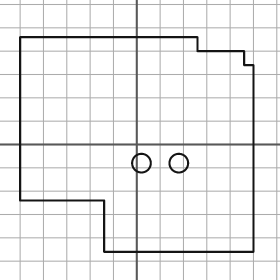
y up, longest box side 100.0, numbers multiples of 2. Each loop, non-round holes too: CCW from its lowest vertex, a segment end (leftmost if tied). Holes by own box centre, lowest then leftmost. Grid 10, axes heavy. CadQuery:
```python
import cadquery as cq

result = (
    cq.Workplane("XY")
    .moveTo(-14.0, -46.0)
    .lineTo(50.0, -46.0)
    .lineTo(50.0, 34.0)
    .lineTo(46.0, 34.0)
    .lineTo(46.0, 40.0)
    .lineTo(26.0, 40.0)
    .lineTo(26.0, 46.0)
    .lineTo(-50.0, 46.0)
    .lineTo(-50.0, -24.0)
    .lineTo(-14.0, -24.0)
    .close()
    .moveTo(2.0, -8.0)
    .circle(4.0)
    .moveTo(18.0, -8.0)
    .circle(4.0)
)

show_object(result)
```